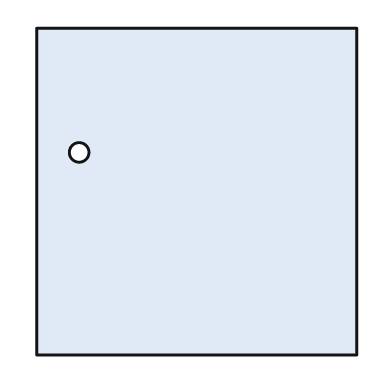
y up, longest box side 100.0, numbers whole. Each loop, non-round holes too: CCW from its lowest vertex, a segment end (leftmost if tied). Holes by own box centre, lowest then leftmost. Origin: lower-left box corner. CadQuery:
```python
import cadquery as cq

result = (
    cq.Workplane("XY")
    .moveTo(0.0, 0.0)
    .lineTo(98.0, 0.0)
    .lineTo(98.0, 100.0)
    .lineTo(0.0, 100.0)
    .close()
    .moveTo(13.0, 62.0)
    .circle(3.0)
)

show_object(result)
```